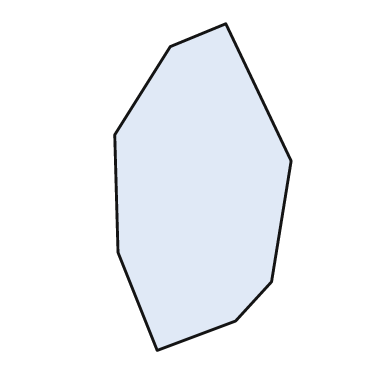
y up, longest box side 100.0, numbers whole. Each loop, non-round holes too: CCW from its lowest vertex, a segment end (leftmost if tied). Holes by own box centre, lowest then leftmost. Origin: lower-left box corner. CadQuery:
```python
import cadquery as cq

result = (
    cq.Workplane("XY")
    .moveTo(13.0, 0.0)
    .lineTo(37.0, 9.0)
    .lineTo(48.0, 21.0)
    .lineTo(54.0, 58.0)
    .lineTo(34.0, 100.0)
    .lineTo(17.0, 93.0)
    .lineTo(0.0, 66.0)
    .lineTo(1.0, 30.0)
    .close()
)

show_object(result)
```